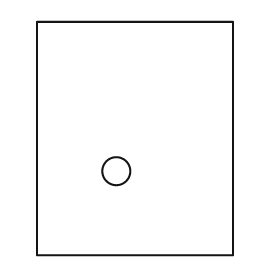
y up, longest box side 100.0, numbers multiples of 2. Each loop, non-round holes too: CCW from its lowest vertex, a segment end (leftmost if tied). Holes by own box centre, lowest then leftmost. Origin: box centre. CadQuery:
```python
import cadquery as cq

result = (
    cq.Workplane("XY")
    .moveTo(-42.0, -50.0)
    .lineTo(42.0, -50.0)
    .lineTo(42.0, 50.0)
    .lineTo(-42.0, 50.0)
    .close()
    .moveTo(-8.0, -14.0)
    .circle(6.0)
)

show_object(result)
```